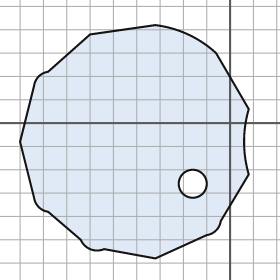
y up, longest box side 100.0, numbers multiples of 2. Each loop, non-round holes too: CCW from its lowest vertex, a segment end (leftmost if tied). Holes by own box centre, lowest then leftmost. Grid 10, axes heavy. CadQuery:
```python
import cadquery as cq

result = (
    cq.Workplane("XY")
    .moveTo(-32.0, -58.0)
    .lineTo(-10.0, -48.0)
    .threePointArc((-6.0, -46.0), (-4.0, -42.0))
    .lineTo(8.0, -22.0)
    .threePointArc((6.0, -8.0), (8.0, 6.0))
    .lineTo(-6.0, 30.0)
    .threePointArc((-18.0, 38.0), (-32.0, 42.0))
    .lineTo(-60.0, 38.0)
    .lineTo(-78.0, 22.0)
    .threePointArc((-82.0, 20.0), (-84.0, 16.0))
    .lineTo(-90.0, -8.0)
    .lineTo(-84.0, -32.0)
    .threePointArc((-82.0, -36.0), (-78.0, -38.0))
    .lineTo(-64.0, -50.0)
    .threePointArc((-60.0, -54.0), (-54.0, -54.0))
    .close()
    .moveTo(-16.0, -26.0)
    .circle(6.0)
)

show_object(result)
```